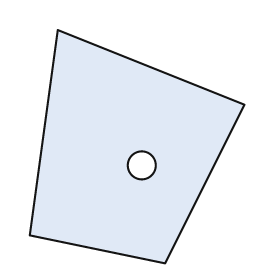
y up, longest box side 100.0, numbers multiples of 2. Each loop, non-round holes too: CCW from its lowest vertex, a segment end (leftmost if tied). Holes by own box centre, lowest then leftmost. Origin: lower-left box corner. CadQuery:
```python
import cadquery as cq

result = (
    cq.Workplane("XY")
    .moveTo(58.0, 0.0)
    .lineTo(92.0, 68.0)
    .lineTo(12.0, 100.0)
    .lineTo(0.0, 12.0)
    .close()
    .moveTo(48.0, 42.0)
    .circle(6.0)
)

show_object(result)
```